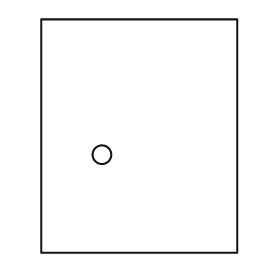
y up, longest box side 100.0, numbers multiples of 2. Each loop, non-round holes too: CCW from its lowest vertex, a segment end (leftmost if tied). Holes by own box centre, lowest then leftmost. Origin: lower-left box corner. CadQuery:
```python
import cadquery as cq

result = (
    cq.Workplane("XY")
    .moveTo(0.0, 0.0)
    .lineTo(84.0, 0.0)
    .lineTo(84.0, 100.0)
    .lineTo(0.0, 100.0)
    .close()
    .moveTo(26.0, 42.0)
    .circle(4.0)
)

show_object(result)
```